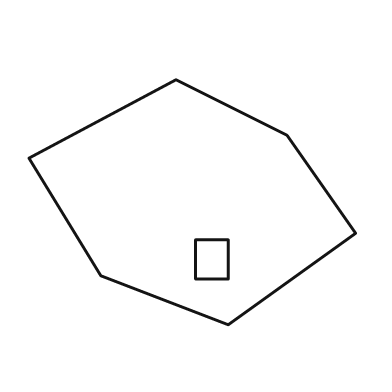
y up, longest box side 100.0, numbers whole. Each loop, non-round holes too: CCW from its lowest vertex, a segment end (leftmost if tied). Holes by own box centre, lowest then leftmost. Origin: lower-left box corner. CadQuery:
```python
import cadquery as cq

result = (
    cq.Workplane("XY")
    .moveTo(61.0, 0.0)
    .lineTo(100.0, 28.0)
    .lineTo(79.0, 58.0)
    .lineTo(45.0, 75.0)
    .lineTo(0.0, 51.0)
    .lineTo(22.0, 15.0)
    .close()
    .moveTo(51.0, 14.0)
    .lineTo(61.0, 14.0)
    .lineTo(61.0, 26.0)
    .lineTo(51.0, 26.0)
    .close()
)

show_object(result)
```